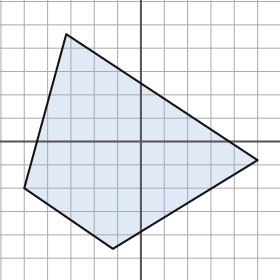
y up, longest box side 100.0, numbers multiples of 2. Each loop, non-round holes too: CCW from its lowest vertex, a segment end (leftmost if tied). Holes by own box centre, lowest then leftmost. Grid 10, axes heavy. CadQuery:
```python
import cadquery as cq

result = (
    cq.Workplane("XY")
    .moveTo(-12.0, -46.0)
    .lineTo(50.0, -8.0)
    .lineTo(-32.0, 46.0)
    .lineTo(-50.0, -20.0)
    .close()
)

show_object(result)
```